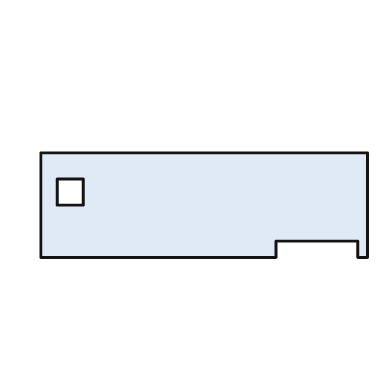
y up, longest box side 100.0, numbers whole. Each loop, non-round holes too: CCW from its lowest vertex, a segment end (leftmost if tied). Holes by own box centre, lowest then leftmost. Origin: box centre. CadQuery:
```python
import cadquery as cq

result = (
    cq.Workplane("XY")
    .moveTo(-50.0, -16.0)
    .lineTo(22.0, -16.0)
    .lineTo(22.0, -11.0)
    .lineTo(47.0, -11.0)
    .lineTo(47.0, -16.0)
    .lineTo(50.0, -16.0)
    .lineTo(50.0, 16.0)
    .lineTo(-50.0, 16.0)
    .close()
    .moveTo(-45.0, 0.0)
    .lineTo(-37.0, 0.0)
    .lineTo(-37.0, 8.0)
    .lineTo(-45.0, 8.0)
    .close()
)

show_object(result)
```